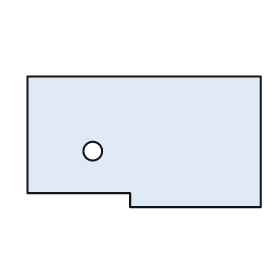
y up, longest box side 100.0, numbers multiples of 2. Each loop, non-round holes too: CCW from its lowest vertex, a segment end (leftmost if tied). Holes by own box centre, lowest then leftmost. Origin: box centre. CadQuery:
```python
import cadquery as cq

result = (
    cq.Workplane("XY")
    .moveTo(-6.0, -28.0)
    .lineTo(50.0, -28.0)
    .lineTo(50.0, 28.0)
    .lineTo(-50.0, 28.0)
    .lineTo(-50.0, -22.0)
    .lineTo(-6.0, -22.0)
    .close()
    .moveTo(-22.0, -4.0)
    .circle(4.0)
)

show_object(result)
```